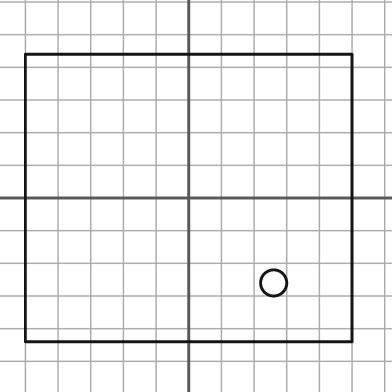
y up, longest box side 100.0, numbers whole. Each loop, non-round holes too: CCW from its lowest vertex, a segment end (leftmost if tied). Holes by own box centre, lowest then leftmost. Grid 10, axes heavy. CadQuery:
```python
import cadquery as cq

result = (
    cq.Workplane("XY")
    .moveTo(-50.0, -44.0)
    .lineTo(50.0, -44.0)
    .lineTo(50.0, 44.0)
    .lineTo(-50.0, 44.0)
    .close()
    .moveTo(26.0, -26.0)
    .circle(4.0)
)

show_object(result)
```